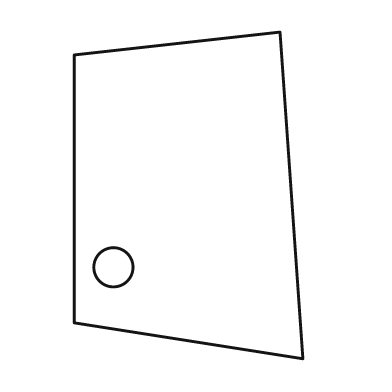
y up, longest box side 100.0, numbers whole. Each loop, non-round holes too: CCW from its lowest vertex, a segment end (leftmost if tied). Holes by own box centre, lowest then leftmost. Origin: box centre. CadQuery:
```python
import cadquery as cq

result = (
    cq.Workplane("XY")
    .moveTo(35.0, -50.0)
    .lineTo(28.0, 50.0)
    .lineTo(-35.0, 43.0)
    .lineTo(-35.0, -39.0)
    .close()
    .moveTo(-23.0, -22.0)
    .circle(6.0)
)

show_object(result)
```